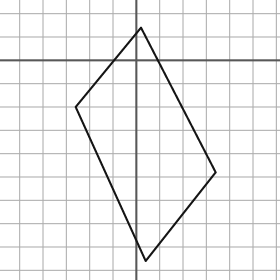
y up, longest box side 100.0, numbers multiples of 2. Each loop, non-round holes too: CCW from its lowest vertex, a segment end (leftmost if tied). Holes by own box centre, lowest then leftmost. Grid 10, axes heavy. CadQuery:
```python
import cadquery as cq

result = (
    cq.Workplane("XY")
    .moveTo(4.0, -86.0)
    .lineTo(34.0, -48.0)
    .lineTo(2.0, 14.0)
    .lineTo(-26.0, -20.0)
    .close()
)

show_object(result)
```